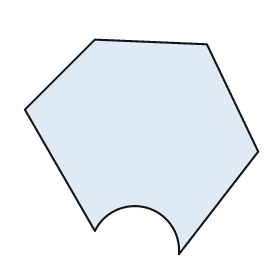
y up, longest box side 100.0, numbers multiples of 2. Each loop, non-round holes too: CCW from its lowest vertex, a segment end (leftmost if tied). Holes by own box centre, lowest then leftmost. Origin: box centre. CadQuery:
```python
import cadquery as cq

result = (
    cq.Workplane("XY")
    .moveTo(16.0, -46.0)
    .lineTo(50.0, -2.0)
    .lineTo(28.0, 44.0)
    .lineTo(-20.0, 46.0)
    .lineTo(-50.0, 16.0)
    .lineTo(-20.0, -36.0)
    .threePointArc((2.0, -26.0), (16.0, -46.0))
    .close()
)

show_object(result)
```